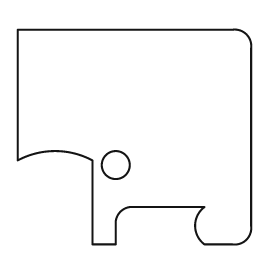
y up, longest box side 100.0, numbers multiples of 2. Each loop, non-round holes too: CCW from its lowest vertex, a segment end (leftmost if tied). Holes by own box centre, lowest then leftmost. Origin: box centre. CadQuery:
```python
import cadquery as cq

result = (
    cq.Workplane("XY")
    .moveTo(-18.0, -46.0)
    .lineTo(-8.0, -46.0)
    .lineTo(-8.0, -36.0)
    .threePointArc((-6.0, -32.0), (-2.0, -30.0))
    .lineTo(30.0, -30.0)
    .threePointArc((26.0, -38.0), (30.0, -46.0))
    .lineTo(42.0, -46.0)
    .threePointArc((48.0, -44.0), (50.0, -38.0))
    .lineTo(50.0, 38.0)
    .threePointArc((48.0, 44.0), (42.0, 46.0))
    .lineTo(-50.0, 46.0)
    .lineTo(-50.0, -10.0)
    .threePointArc((-34.0, -6.0), (-18.0, -10.0))
    .close()
    .moveTo(-8.0, -12.0)
    .circle(6.0)
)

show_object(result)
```